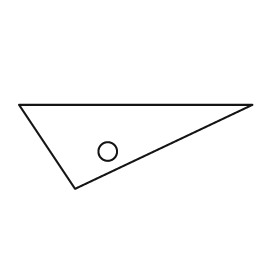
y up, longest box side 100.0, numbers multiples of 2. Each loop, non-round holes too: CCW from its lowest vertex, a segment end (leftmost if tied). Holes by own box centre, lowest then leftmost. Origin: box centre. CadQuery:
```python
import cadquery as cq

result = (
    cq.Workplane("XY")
    .moveTo(-26.0, -18.0)
    .lineTo(50.0, 18.0)
    .lineTo(-50.0, 18.0)
    .close()
    .moveTo(-12.0, -2.0)
    .circle(4.0)
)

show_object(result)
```